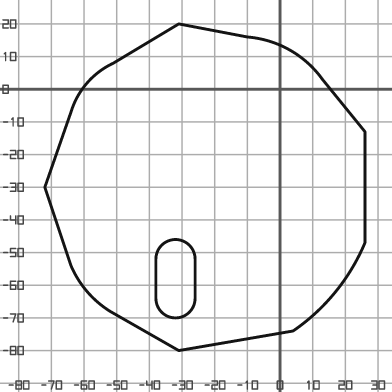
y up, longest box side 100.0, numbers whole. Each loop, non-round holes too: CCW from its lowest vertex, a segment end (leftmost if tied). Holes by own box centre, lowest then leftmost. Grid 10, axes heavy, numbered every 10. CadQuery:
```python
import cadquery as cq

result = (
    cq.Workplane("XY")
    .moveTo(-31.0, -80.0)
    .lineTo(4.0, -74.0)
    .threePointArc((17.0, -62.0), (26.0, -47.0))
    .lineTo(26.0, -13.0)
    .lineTo(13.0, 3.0)
    .threePointArc((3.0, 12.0), (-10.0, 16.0))
    .lineTo(-31.0, 20.0)
    .lineTo(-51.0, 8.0)
    .threePointArc((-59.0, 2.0), (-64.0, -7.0))
    .lineTo(-72.0, -30.0)
    .lineTo(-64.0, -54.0)
    .threePointArc((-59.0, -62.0), (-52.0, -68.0))
    .close()
    .moveTo(-38.0, -64.0)
    .threePointArc((-32.0, -70.0), (-26.0, -64.0))
    .lineTo(-26.0, -52.0)
    .threePointArc((-32.0, -46.0), (-38.0, -52.0))
    .close()
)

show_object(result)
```